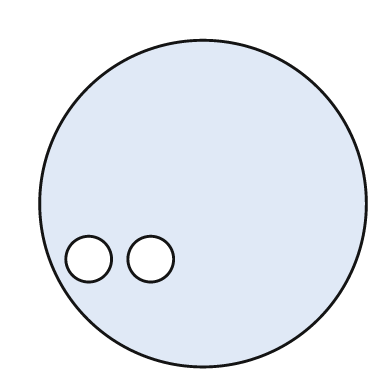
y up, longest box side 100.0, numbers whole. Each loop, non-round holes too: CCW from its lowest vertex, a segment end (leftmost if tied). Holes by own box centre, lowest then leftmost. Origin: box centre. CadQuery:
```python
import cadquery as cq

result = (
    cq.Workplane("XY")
    .moveTo(0.0, 0.0)
    .circle(50.0)
    .moveTo(-35.0, -17.0)
    .circle(7.0)
    .moveTo(-16.0, -17.0)
    .circle(7.0)
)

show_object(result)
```